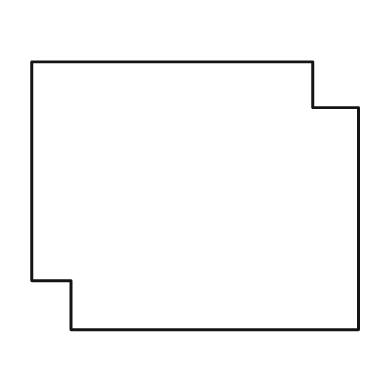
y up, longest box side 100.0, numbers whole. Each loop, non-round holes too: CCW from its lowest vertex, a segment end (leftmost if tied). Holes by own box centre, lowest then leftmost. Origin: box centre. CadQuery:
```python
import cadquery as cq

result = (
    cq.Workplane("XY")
    .moveTo(-38.0, -41.0)
    .lineTo(50.0, -41.0)
    .lineTo(50.0, 27.0)
    .lineTo(36.0, 27.0)
    .lineTo(36.0, 41.0)
    .lineTo(-50.0, 41.0)
    .lineTo(-50.0, -26.0)
    .lineTo(-38.0, -26.0)
    .close()
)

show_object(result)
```